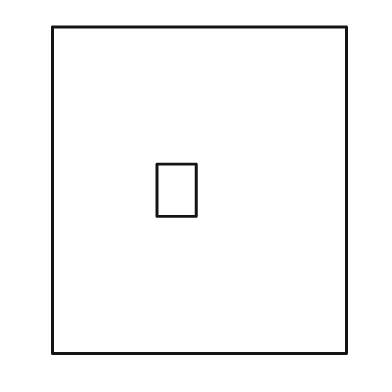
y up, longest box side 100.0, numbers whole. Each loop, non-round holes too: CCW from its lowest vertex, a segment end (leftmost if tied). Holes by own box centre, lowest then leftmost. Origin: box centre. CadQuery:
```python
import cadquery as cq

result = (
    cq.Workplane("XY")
    .moveTo(-45.0, -50.0)
    .lineTo(45.0, -50.0)
    .lineTo(45.0, 50.0)
    .lineTo(-45.0, 50.0)
    .close()
    .moveTo(-13.0, -8.0)
    .lineTo(-1.0, -8.0)
    .lineTo(-1.0, 8.0)
    .lineTo(-13.0, 8.0)
    .close()
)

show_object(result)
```